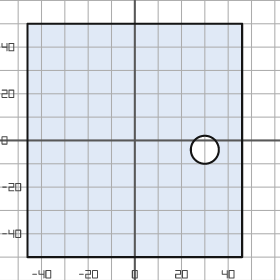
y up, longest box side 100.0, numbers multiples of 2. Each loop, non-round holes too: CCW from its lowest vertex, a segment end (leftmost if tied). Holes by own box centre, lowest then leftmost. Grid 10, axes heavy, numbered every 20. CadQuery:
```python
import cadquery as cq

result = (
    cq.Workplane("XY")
    .moveTo(-46.0, -50.0)
    .lineTo(46.0, -50.0)
    .lineTo(46.0, 50.0)
    .lineTo(-46.0, 50.0)
    .close()
    .moveTo(30.0, -4.0)
    .circle(6.0)
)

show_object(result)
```